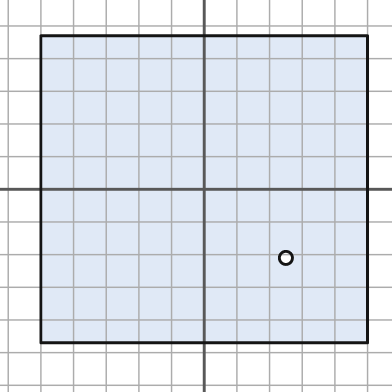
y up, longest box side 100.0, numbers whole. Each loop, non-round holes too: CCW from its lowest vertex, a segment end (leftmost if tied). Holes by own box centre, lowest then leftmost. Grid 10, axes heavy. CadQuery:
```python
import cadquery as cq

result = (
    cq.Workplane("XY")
    .moveTo(-50.0, -47.0)
    .lineTo(50.0, -47.0)
    .lineTo(50.0, 47.0)
    .lineTo(-50.0, 47.0)
    .close()
    .moveTo(25.0, -21.0)
    .circle(2.0)
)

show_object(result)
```